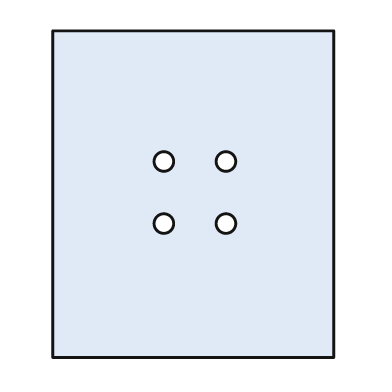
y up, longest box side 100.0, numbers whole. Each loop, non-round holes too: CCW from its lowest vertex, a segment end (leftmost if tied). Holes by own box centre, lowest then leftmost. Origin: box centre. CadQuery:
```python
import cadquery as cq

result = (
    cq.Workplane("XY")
    .moveTo(-43.0, -50.0)
    .lineTo(43.0, -50.0)
    .lineTo(43.0, 50.0)
    .lineTo(-43.0, 50.0)
    .close()
    .moveTo(-9.0, -9.0)
    .circle(3.0)
    .moveTo(10.0, -9.0)
    .circle(3.0)
    .moveTo(-9.0, 10.0)
    .circle(3.0)
    .moveTo(10.0, 10.0)
    .circle(3.0)
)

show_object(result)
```